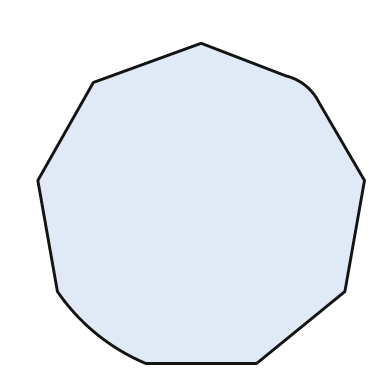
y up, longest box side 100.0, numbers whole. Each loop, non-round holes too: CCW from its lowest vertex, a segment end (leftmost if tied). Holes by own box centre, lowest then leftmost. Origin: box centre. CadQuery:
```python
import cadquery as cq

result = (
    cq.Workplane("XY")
    .moveTo(-17.0, -49.0)
    .lineTo(17.0, -49.0)
    .lineTo(44.0, -27.0)
    .lineTo(50.0, 7.0)
    .lineTo(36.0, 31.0)
    .threePointArc((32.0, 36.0), (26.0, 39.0))
    .lineTo(0.0, 49.0)
    .lineTo(-33.0, 37.0)
    .lineTo(-50.0, 7.0)
    .lineTo(-44.0, -27.0)
    .threePointArc((-32.0, -40.0), (-17.0, -49.0))
    .close()
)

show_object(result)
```